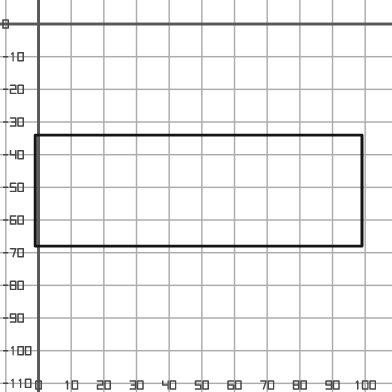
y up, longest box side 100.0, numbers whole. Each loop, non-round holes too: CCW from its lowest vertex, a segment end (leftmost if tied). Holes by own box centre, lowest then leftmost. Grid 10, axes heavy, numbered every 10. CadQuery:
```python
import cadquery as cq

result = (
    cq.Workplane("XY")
    .moveTo(-1.0, -68.0)
    .lineTo(99.0, -68.0)
    .lineTo(99.0, -34.0)
    .lineTo(-1.0, -34.0)
    .close()
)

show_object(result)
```